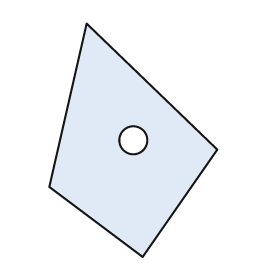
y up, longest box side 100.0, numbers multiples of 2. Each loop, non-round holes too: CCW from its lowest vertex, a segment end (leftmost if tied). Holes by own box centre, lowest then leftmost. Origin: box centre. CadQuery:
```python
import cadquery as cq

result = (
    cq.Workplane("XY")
    .moveTo(4.0, -50.0)
    .lineTo(36.0, -4.0)
    .lineTo(-20.0, 50.0)
    .lineTo(-36.0, -20.0)
    .close()
    .moveTo(0.0, 0.0)
    .circle(6.0)
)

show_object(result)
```